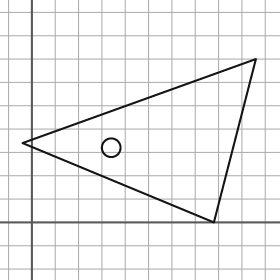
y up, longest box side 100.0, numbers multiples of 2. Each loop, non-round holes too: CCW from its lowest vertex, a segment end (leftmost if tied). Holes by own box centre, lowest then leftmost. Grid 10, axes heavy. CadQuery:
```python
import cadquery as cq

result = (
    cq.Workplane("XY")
    .moveTo(78.0, 0.0)
    .lineTo(96.0, 70.0)
    .lineTo(-4.0, 34.0)
    .close()
    .moveTo(34.0, 32.0)
    .circle(4.0)
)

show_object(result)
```